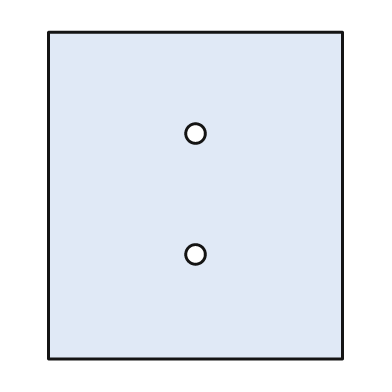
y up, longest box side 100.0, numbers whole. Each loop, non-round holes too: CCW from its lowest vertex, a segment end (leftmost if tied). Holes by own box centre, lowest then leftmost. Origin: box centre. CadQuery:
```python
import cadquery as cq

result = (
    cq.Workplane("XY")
    .moveTo(-45.0, -50.0)
    .lineTo(45.0, -50.0)
    .lineTo(45.0, 50.0)
    .lineTo(-45.0, 50.0)
    .close()
    .moveTo(0.0, -18.0)
    .circle(3.0)
    .moveTo(0.0, 19.0)
    .circle(3.0)
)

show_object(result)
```